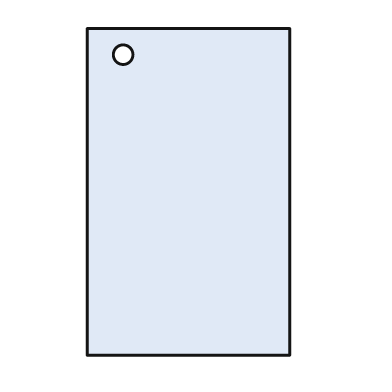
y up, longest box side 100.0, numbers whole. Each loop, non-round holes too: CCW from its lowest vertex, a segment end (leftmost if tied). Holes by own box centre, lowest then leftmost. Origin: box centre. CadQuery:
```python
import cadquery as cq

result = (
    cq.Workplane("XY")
    .moveTo(-31.0, -50.0)
    .lineTo(31.0, -50.0)
    .lineTo(31.0, 50.0)
    .lineTo(-31.0, 50.0)
    .close()
    .moveTo(-20.0, 42.0)
    .circle(3.0)
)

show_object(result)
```